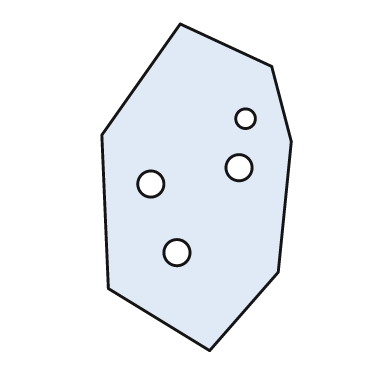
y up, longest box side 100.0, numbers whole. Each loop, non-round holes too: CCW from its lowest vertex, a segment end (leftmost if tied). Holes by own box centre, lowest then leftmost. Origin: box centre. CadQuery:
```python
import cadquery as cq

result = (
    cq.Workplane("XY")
    .moveTo(4.0, -50.0)
    .lineTo(25.0, -26.0)
    .lineTo(29.0, 14.0)
    .lineTo(23.0, 37.0)
    .lineTo(-5.0, 50.0)
    .lineTo(-29.0, 16.0)
    .lineTo(-27.0, -31.0)
    .close()
    .moveTo(-6.0, -20.0)
    .circle(4.0)
    .moveTo(-14.0, 1.0)
    .circle(4.0)
    .moveTo(13.0, 6.0)
    .circle(4.0)
    .moveTo(15.0, 21.0)
    .circle(3.0)
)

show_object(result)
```